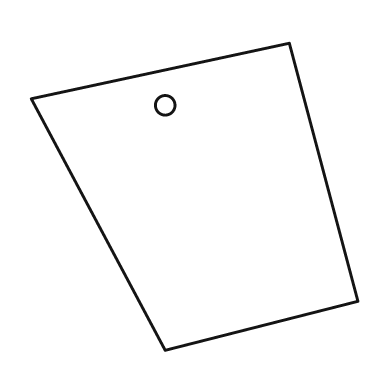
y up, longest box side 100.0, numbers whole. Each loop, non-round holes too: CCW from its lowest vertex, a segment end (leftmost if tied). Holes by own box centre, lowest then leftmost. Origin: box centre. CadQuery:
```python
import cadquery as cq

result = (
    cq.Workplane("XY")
    .moveTo(-9.0, -47.0)
    .lineTo(50.0, -32.0)
    .lineTo(29.0, 47.0)
    .lineTo(-50.0, 30.0)
    .close()
    .moveTo(-9.0, 28.0)
    .circle(3.0)
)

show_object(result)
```